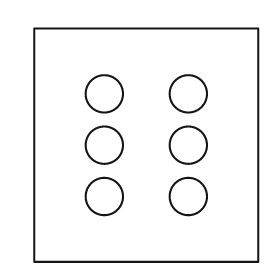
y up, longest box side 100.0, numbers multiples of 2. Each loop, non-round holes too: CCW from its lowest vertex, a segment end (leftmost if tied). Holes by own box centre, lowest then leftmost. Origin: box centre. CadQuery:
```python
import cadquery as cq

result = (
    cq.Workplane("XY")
    .moveTo(-48.0, -50.0)
    .lineTo(48.0, -50.0)
    .lineTo(48.0, 50.0)
    .lineTo(-48.0, 50.0)
    .close()
    .moveTo(-18.0, -22.0)
    .circle(8.0)
    .moveTo(18.0, -22.0)
    .circle(8.0)
    .moveTo(-18.0, 0.0)
    .circle(8.0)
    .moveTo(18.0, 0.0)
    .circle(8.0)
    .moveTo(-18.0, 22.0)
    .circle(8.0)
    .moveTo(18.0, 22.0)
    .circle(8.0)
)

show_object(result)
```